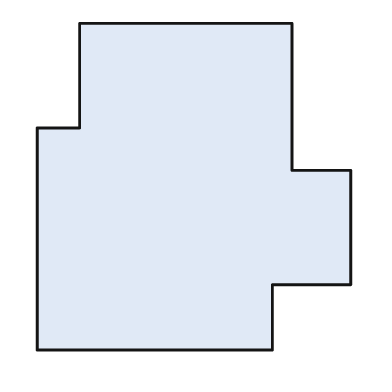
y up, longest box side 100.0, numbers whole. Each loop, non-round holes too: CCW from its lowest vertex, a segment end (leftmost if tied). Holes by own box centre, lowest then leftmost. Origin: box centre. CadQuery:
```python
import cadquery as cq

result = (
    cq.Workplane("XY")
    .moveTo(-48.0, -50.0)
    .lineTo(24.0, -50.0)
    .lineTo(24.0, -30.0)
    .lineTo(48.0, -30.0)
    .lineTo(48.0, 5.0)
    .lineTo(30.0, 5.0)
    .lineTo(30.0, 50.0)
    .lineTo(-35.0, 50.0)
    .lineTo(-35.0, 18.0)
    .lineTo(-48.0, 18.0)
    .close()
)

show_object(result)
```